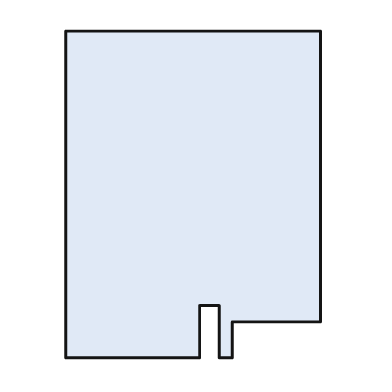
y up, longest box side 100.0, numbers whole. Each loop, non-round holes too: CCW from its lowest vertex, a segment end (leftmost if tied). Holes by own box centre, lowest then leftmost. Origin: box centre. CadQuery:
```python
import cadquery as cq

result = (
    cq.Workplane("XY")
    .moveTo(-39.0, -50.0)
    .lineTo(2.0, -50.0)
    .lineTo(2.0, -34.0)
    .lineTo(8.0, -34.0)
    .lineTo(8.0, -50.0)
    .lineTo(12.0, -50.0)
    .lineTo(12.0, -39.0)
    .lineTo(39.0, -39.0)
    .lineTo(39.0, 50.0)
    .lineTo(-39.0, 50.0)
    .close()
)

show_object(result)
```